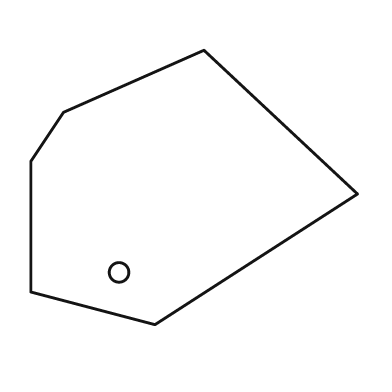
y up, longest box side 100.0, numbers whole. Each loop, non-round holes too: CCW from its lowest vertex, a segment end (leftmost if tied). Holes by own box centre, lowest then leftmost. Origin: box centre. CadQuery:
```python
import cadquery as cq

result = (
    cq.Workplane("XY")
    .moveTo(-12.0, -42.0)
    .lineTo(50.0, -2.0)
    .lineTo(3.0, 42.0)
    .lineTo(-40.0, 23.0)
    .lineTo(-50.0, 8.0)
    .lineTo(-50.0, -32.0)
    .close()
    .moveTo(-23.0, -26.0)
    .circle(3.0)
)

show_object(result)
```